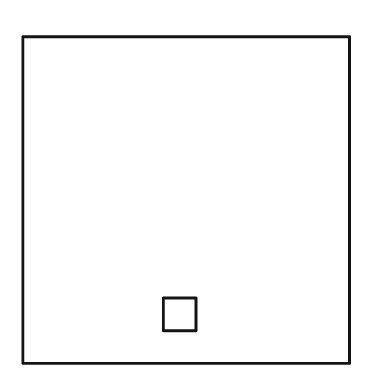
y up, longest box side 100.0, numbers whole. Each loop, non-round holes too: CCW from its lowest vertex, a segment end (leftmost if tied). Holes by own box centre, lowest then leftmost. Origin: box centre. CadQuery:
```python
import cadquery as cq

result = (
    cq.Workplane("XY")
    .moveTo(-50.0, -50.0)
    .lineTo(50.0, -50.0)
    .lineTo(50.0, 50.0)
    .lineTo(-50.0, 50.0)
    .close()
    .moveTo(-7.0, -40.0)
    .lineTo(3.0, -40.0)
    .lineTo(3.0, -30.0)
    .lineTo(-7.0, -30.0)
    .close()
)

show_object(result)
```